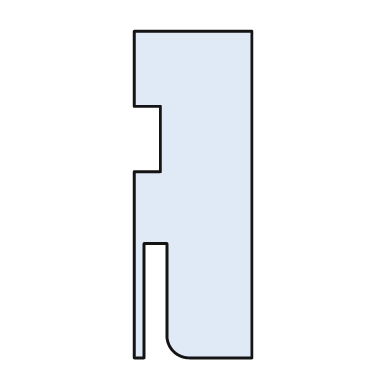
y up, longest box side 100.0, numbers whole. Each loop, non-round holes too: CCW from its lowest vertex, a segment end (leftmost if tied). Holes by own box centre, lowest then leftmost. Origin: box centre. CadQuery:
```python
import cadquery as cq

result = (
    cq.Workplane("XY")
    .moveTo(-18.0, -50.0)
    .lineTo(-15.0, -50.0)
    .lineTo(-15.0, -15.0)
    .lineTo(-8.0, -15.0)
    .lineTo(-8.0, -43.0)
    .threePointArc((-6.0, -48.0), (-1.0, -50.0))
    .lineTo(18.0, -50.0)
    .lineTo(18.0, 50.0)
    .lineTo(-18.0, 50.0)
    .lineTo(-18.0, 27.0)
    .lineTo(-10.0, 27.0)
    .lineTo(-10.0, 7.0)
    .lineTo(-18.0, 7.0)
    .close()
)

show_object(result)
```